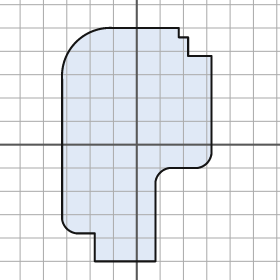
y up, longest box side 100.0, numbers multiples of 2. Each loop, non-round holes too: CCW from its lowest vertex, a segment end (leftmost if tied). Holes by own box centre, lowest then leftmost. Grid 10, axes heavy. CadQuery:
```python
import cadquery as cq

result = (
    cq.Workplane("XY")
    .moveTo(-18.0, -50.0)
    .lineTo(8.0, -50.0)
    .lineTo(8.0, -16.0)
    .threePointArc((10.0, -12.0), (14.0, -10.0))
    .lineTo(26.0, -10.0)
    .threePointArc((30.0, -8.0), (32.0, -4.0))
    .lineTo(32.0, 38.0)
    .lineTo(22.0, 38.0)
    .lineTo(22.0, 46.0)
    .lineTo(18.0, 46.0)
    .lineTo(18.0, 50.0)
    .lineTo(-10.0, 50.0)
    .threePointArc((-26.0, 44.0), (-32.0, 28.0))
    .lineTo(-32.0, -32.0)
    .threePointArc((-30.0, -36.0), (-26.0, -38.0))
    .lineTo(-18.0, -38.0)
    .close()
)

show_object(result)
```